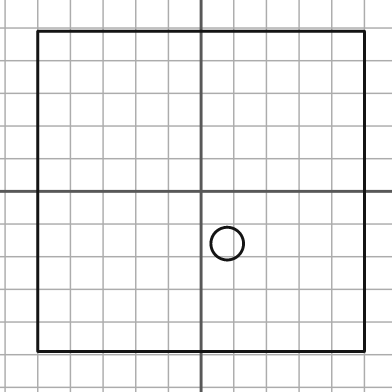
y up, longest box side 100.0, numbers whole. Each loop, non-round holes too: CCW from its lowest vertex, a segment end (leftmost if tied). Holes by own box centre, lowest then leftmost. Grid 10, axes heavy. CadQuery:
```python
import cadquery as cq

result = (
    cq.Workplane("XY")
    .moveTo(-50.0, -49.0)
    .lineTo(50.0, -49.0)
    .lineTo(50.0, 49.0)
    .lineTo(-50.0, 49.0)
    .close()
    .moveTo(8.0, -16.0)
    .circle(5.0)
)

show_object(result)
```